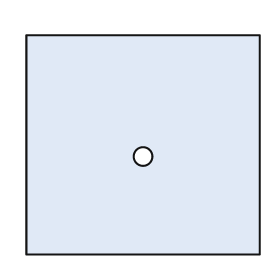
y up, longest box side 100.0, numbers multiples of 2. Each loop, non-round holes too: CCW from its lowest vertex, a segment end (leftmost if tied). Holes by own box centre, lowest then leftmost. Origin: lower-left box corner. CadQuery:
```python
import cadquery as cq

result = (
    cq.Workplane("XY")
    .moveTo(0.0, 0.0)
    .lineTo(100.0, 0.0)
    .lineTo(100.0, 94.0)
    .lineTo(0.0, 94.0)
    .close()
    .moveTo(50.0, 42.0)
    .circle(4.0)
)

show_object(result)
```